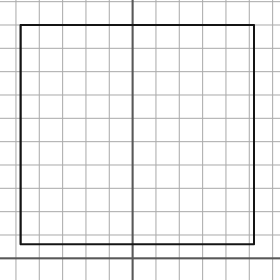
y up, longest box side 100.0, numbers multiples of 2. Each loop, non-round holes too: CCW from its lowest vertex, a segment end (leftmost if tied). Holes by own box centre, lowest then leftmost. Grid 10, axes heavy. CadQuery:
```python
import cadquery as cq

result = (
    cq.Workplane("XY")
    .moveTo(-48.0, 6.0)
    .lineTo(52.0, 6.0)
    .lineTo(52.0, 100.0)
    .lineTo(-48.0, 100.0)
    .close()
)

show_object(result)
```